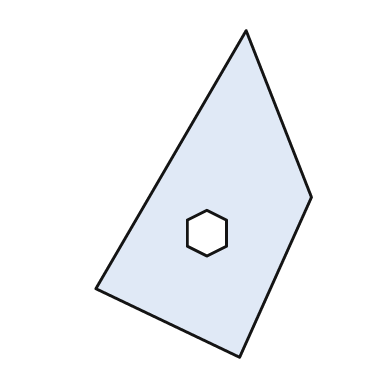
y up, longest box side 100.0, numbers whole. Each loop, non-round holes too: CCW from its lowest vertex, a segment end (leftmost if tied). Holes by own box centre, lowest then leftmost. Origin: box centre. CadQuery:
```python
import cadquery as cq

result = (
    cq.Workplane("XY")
    .moveTo(11.0, -50.0)
    .lineTo(33.0, -1.0)
    .lineTo(13.0, 50.0)
    .lineTo(-33.0, -29.0)
    .close()
    .moveTo(1.0, -19.0)
    .lineTo(7.0, -16.0)
    .lineTo(7.0, -8.0)
    .lineTo(1.0, -5.0)
    .lineTo(-5.0, -8.0)
    .lineTo(-5.0, -16.0)
    .close()
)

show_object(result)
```